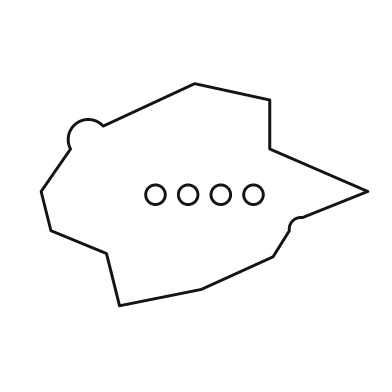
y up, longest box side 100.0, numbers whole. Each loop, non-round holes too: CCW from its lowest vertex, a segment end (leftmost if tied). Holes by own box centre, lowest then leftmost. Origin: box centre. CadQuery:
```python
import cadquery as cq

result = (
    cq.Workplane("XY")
    .moveTo(-26.0, -34.0)
    .lineTo(-1.0, -29.0)
    .lineTo(21.0, -19.0)
    .lineTo(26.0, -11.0)
    .threePointArc((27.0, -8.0), (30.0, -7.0))
    .lineTo(50.0, 1.0)
    .lineTo(20.0, 14.0)
    .lineTo(20.0, 29.0)
    .lineTo(-3.0, 34.0)
    .lineTo(-31.0, 21.0)
    .threePointArc((-39.0, 22.0), (-41.0, 14.0))
    .lineTo(-50.0, 1.0)
    .lineTo(-47.0, -11.0)
    .lineTo(-30.0, -18.0)
    .close()
    .moveTo(-15.0, 0.0)
    .circle(3.0)
    .moveTo(-5.0, 0.0)
    .circle(3.0)
    .moveTo(5.0, 0.0)
    .circle(3.0)
    .moveTo(15.0, 0.0)
    .circle(3.0)
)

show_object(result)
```